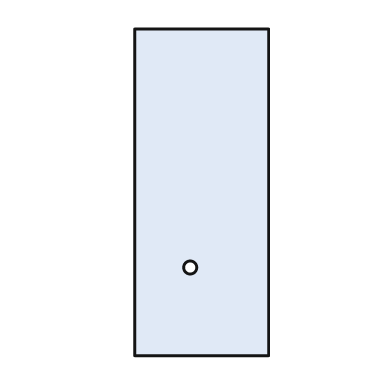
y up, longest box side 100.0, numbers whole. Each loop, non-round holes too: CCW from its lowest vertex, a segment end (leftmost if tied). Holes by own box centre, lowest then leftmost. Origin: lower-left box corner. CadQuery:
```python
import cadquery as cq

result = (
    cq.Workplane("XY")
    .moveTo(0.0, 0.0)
    .lineTo(41.0, 0.0)
    .lineTo(41.0, 100.0)
    .lineTo(0.0, 100.0)
    .close()
    .moveTo(17.0, 27.0)
    .circle(2.0)
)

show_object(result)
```